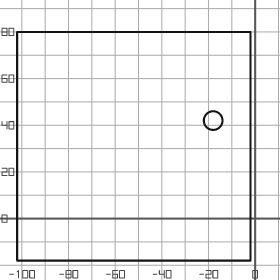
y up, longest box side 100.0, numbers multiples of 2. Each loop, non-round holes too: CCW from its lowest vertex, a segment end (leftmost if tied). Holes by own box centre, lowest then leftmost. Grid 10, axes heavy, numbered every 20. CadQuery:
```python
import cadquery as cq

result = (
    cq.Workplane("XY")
    .moveTo(-102.0, -18.0)
    .lineTo(-2.0, -18.0)
    .lineTo(-2.0, 80.0)
    .lineTo(-102.0, 80.0)
    .close()
    .moveTo(-18.0, 42.0)
    .circle(4.0)
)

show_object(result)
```